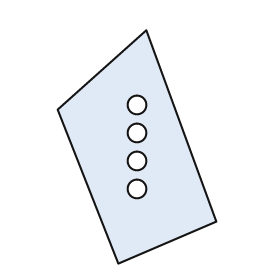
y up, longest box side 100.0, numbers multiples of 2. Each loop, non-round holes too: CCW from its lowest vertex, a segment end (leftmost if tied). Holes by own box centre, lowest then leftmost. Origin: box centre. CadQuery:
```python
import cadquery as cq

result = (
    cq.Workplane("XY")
    .moveTo(-8.0, -50.0)
    .lineTo(34.0, -32.0)
    .lineTo(4.0, 50.0)
    .lineTo(-34.0, 16.0)
    .close()
    .moveTo(0.0, -18.0)
    .circle(4.0)
    .moveTo(0.0, -6.0)
    .circle(4.0)
    .moveTo(0.0, 6.0)
    .circle(4.0)
    .moveTo(0.0, 18.0)
    .circle(4.0)
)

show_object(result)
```